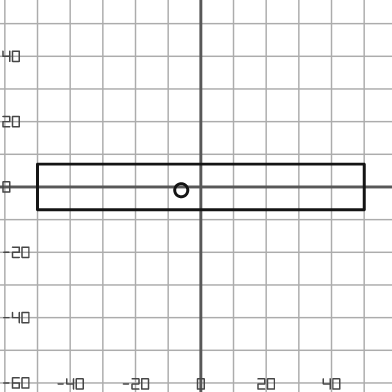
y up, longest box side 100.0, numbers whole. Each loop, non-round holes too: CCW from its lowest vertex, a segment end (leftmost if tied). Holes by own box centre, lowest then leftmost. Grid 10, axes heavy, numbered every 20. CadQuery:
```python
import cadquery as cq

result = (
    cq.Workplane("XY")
    .moveTo(-50.0, -7.0)
    .lineTo(50.0, -7.0)
    .lineTo(50.0, 7.0)
    .lineTo(-50.0, 7.0)
    .close()
    .moveTo(-6.0, -1.0)
    .circle(2.0)
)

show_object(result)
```